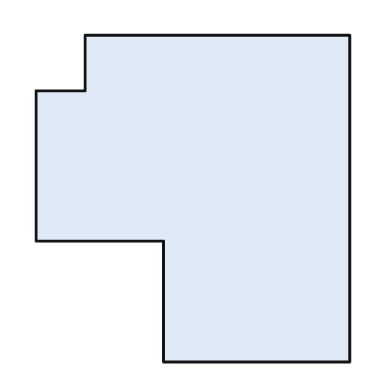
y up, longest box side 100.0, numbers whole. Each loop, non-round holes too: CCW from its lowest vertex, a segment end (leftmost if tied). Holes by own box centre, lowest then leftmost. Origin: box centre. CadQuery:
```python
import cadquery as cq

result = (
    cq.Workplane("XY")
    .moveTo(-9.0, -50.0)
    .lineTo(48.0, -50.0)
    .lineTo(48.0, 50.0)
    .lineTo(-33.0, 50.0)
    .lineTo(-33.0, 33.0)
    .lineTo(-48.0, 33.0)
    .lineTo(-48.0, -13.0)
    .lineTo(-9.0, -13.0)
    .close()
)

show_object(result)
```